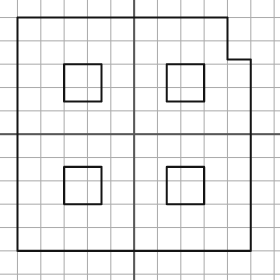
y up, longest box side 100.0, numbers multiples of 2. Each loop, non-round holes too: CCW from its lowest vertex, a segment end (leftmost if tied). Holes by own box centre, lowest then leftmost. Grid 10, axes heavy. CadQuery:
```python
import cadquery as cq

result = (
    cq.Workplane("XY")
    .moveTo(-50.0, -50.0)
    .lineTo(50.0, -50.0)
    .lineTo(50.0, 32.0)
    .lineTo(40.0, 32.0)
    .lineTo(40.0, 50.0)
    .lineTo(-50.0, 50.0)
    .close()
    .moveTo(-30.0, -30.0)
    .lineTo(-14.0, -30.0)
    .lineTo(-14.0, -14.0)
    .lineTo(-30.0, -14.0)
    .close()
    .moveTo(14.0, -30.0)
    .lineTo(30.0, -30.0)
    .lineTo(30.0, -14.0)
    .lineTo(14.0, -14.0)
    .close()
    .moveTo(-30.0, 14.0)
    .lineTo(-14.0, 14.0)
    .lineTo(-14.0, 30.0)
    .lineTo(-30.0, 30.0)
    .close()
    .moveTo(14.0, 14.0)
    .lineTo(30.0, 14.0)
    .lineTo(30.0, 30.0)
    .lineTo(14.0, 30.0)
    .close()
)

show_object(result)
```